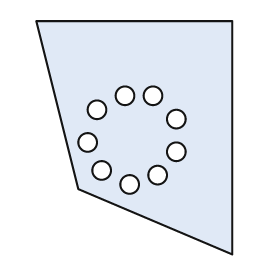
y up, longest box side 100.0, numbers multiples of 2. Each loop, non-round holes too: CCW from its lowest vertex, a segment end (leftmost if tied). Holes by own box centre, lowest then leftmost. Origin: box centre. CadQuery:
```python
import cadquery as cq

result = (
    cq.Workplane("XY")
    .moveTo(42.0, -50.0)
    .lineTo(42.0, 50.0)
    .lineTo(-42.0, 50.0)
    .lineTo(-24.0, -22.0)
    .close()
    .moveTo(-2.0, -20.0)
    .circle(4.0)
    .moveTo(10.0, -16.0)
    .circle(4.0)
    .moveTo(-14.0, -14.0)
    .circle(4.0)
    .moveTo(18.0, -6.0)
    .circle(4.0)
    .moveTo(-20.0, -2.0)
    .circle(4.0)
    .moveTo(18.0, 8.0)
    .circle(4.0)
    .moveTo(-16.0, 12.0)
    .circle(4.0)
    .moveTo(-4.0, 18.0)
    .circle(4.0)
    .moveTo(8.0, 18.0)
    .circle(4.0)
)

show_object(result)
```